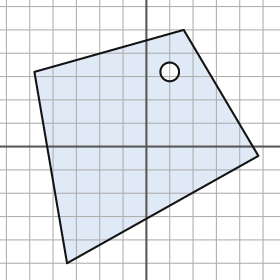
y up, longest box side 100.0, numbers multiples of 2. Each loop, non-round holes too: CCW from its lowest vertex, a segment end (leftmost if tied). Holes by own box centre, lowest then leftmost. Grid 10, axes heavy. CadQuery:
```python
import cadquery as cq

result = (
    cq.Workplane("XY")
    .moveTo(-34.0, -50.0)
    .lineTo(48.0, -4.0)
    .lineTo(16.0, 50.0)
    .lineTo(-48.0, 32.0)
    .close()
    .moveTo(10.0, 32.0)
    .circle(4.0)
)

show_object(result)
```